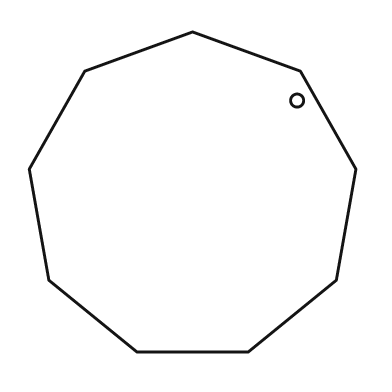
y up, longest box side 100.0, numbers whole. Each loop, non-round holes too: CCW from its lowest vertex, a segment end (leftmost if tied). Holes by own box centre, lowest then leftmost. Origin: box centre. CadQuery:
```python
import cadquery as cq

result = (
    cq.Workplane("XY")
    .moveTo(-17.0, -49.0)
    .lineTo(17.0, -49.0)
    .lineTo(44.0, -27.0)
    .lineTo(50.0, 7.0)
    .lineTo(33.0, 37.0)
    .lineTo(0.0, 49.0)
    .lineTo(-33.0, 37.0)
    .lineTo(-50.0, 7.0)
    .lineTo(-44.0, -27.0)
    .close()
    .moveTo(32.0, 28.0)
    .circle(2.0)
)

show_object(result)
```